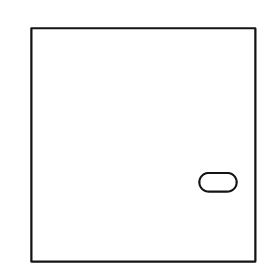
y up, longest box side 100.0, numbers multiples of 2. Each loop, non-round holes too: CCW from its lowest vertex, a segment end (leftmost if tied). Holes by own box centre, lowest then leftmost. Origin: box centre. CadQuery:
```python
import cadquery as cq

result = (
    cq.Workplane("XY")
    .moveTo(-48.0, -50.0)
    .lineTo(48.0, -50.0)
    .lineTo(48.0, 50.0)
    .lineTo(-48.0, 50.0)
    .close()
    .moveTo(28.0, -20.0)
    .lineTo(36.0, -20.0)
    .threePointArc((40.0, -16.0), (36.0, -12.0))
    .lineTo(28.0, -12.0)
    .threePointArc((24.0, -16.0), (28.0, -20.0))
    .close()
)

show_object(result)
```